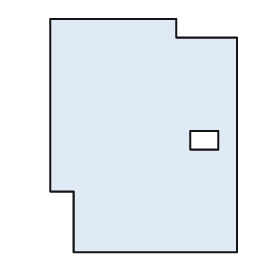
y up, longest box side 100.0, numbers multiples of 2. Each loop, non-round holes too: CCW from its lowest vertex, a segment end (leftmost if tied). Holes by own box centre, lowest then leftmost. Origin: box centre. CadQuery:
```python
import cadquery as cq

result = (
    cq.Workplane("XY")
    .moveTo(-30.0, -50.0)
    .lineTo(40.0, -50.0)
    .lineTo(40.0, 42.0)
    .lineTo(14.0, 42.0)
    .lineTo(14.0, 50.0)
    .lineTo(-40.0, 50.0)
    .lineTo(-40.0, -24.0)
    .lineTo(-30.0, -24.0)
    .close()
    .moveTo(20.0, -6.0)
    .lineTo(32.0, -6.0)
    .lineTo(32.0, 2.0)
    .lineTo(20.0, 2.0)
    .close()
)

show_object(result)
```